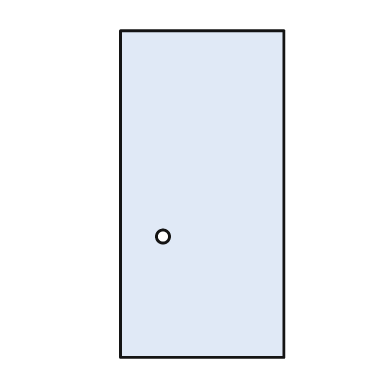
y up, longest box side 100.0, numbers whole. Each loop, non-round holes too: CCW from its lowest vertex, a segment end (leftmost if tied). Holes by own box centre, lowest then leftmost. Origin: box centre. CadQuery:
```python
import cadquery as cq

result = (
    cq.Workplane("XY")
    .moveTo(-25.0, -50.0)
    .lineTo(25.0, -50.0)
    .lineTo(25.0, 50.0)
    .lineTo(-25.0, 50.0)
    .close()
    .moveTo(-12.0, -13.0)
    .circle(2.0)
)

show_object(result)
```